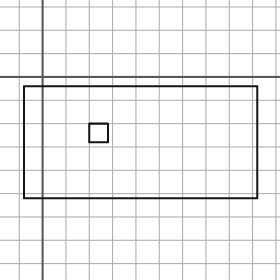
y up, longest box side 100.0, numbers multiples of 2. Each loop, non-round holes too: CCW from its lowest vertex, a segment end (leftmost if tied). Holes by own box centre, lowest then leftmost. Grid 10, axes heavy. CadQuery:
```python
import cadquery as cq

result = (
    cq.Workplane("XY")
    .moveTo(-8.0, -52.0)
    .lineTo(92.0, -52.0)
    .lineTo(92.0, -4.0)
    .lineTo(-8.0, -4.0)
    .close()
    .moveTo(20.0, -28.0)
    .lineTo(28.0, -28.0)
    .lineTo(28.0, -20.0)
    .lineTo(20.0, -20.0)
    .close()
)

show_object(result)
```